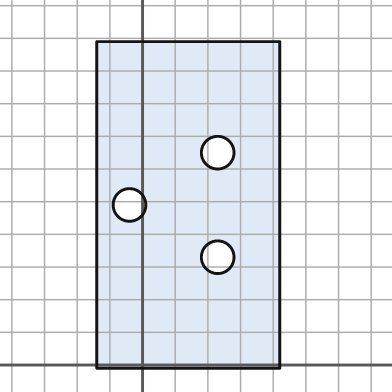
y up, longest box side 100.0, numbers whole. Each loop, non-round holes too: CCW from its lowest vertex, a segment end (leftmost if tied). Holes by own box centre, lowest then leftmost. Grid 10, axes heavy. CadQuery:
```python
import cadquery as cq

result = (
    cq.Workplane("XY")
    .moveTo(-14.0, -1.0)
    .lineTo(42.0, -1.0)
    .lineTo(42.0, 99.0)
    .lineTo(-14.0, 99.0)
    .close()
    .moveTo(23.0, 33.0)
    .circle(5.0)
    .moveTo(-4.0, 49.0)
    .circle(5.0)
    .moveTo(23.0, 65.0)
    .circle(5.0)
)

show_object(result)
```